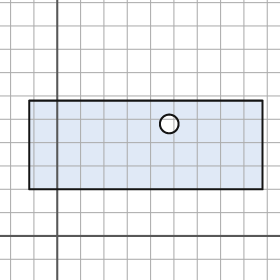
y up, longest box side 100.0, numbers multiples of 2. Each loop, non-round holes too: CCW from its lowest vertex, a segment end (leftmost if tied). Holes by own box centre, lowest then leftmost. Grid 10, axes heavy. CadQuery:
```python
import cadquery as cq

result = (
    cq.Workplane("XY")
    .moveTo(-12.0, 20.0)
    .lineTo(88.0, 20.0)
    .lineTo(88.0, 58.0)
    .lineTo(-12.0, 58.0)
    .close()
    .moveTo(48.0, 48.0)
    .circle(4.0)
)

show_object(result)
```